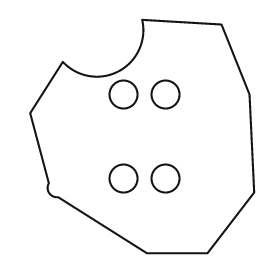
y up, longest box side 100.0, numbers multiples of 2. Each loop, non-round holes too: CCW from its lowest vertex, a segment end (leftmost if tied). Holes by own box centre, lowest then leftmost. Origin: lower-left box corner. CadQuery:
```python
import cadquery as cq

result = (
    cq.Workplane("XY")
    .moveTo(50.0, 0.0)
    .lineTo(76.0, 0.0)
    .lineTo(96.0, 26.0)
    .lineTo(94.0, 68.0)
    .lineTo(82.0, 98.0)
    .lineTo(48.0, 100.0)
    .threePointArc((38.0, 78.0), (14.0, 82.0))
    .lineTo(0.0, 60.0)
    .lineTo(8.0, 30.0)
    .threePointArc((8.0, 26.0), (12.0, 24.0))
    .close()
    .moveTo(40.0, 32.0)
    .circle(6.0)
    .moveTo(58.0, 32.0)
    .circle(6.0)
    .moveTo(40.0, 68.0)
    .circle(6.0)
    .moveTo(58.0, 68.0)
    .circle(6.0)
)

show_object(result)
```